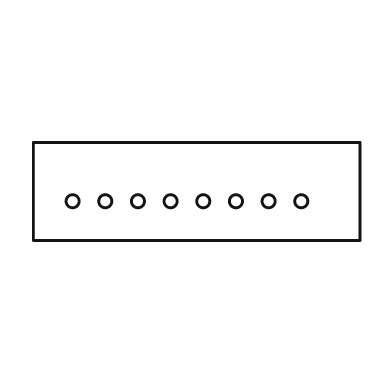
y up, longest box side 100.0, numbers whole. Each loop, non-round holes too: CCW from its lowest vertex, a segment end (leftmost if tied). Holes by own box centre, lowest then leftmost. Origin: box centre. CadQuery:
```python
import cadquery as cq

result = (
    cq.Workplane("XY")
    .moveTo(-50.0, -15.0)
    .lineTo(50.0, -15.0)
    .lineTo(50.0, 15.0)
    .lineTo(-50.0, 15.0)
    .close()
    .moveTo(-38.0, -3.0)
    .circle(2.0)
    .moveTo(-28.0, -3.0)
    .circle(2.0)
    .moveTo(-18.0, -3.0)
    .circle(2.0)
    .moveTo(-8.0, -3.0)
    .circle(2.0)
    .moveTo(2.0, -3.0)
    .circle(2.0)
    .moveTo(12.0, -3.0)
    .circle(2.0)
    .moveTo(22.0, -3.0)
    .circle(2.0)
    .moveTo(32.0, -3.0)
    .circle(2.0)
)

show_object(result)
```